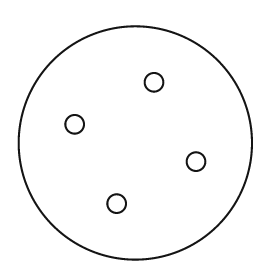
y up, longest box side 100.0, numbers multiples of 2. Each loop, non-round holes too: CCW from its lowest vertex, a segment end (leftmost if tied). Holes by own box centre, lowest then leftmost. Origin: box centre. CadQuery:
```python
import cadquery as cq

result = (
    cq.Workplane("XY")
    .moveTo(0.0, 0.0)
    .circle(50.0)
    .moveTo(-8.0, -26.0)
    .circle(4.0)
    .moveTo(26.0, -8.0)
    .circle(4.0)
    .moveTo(-26.0, 8.0)
    .circle(4.0)
    .moveTo(8.0, 26.0)
    .circle(4.0)
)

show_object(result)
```